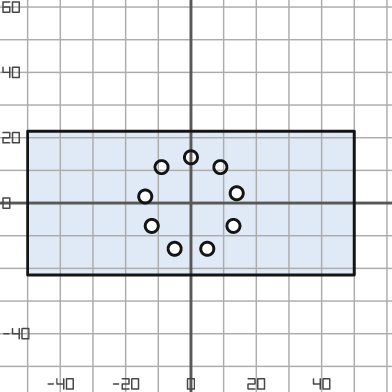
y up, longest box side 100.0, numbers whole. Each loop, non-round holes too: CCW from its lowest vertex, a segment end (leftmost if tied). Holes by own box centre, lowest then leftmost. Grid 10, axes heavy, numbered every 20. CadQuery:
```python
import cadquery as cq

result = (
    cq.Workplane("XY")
    .moveTo(-50.0, -22.0)
    .lineTo(50.0, -22.0)
    .lineTo(50.0, 22.0)
    .lineTo(-50.0, 22.0)
    .close()
    .moveTo(-5.0, -14.0)
    .circle(2.0)
    .moveTo(5.0, -14.0)
    .circle(2.0)
    .moveTo(-12.0, -7.0)
    .circle(2.0)
    .moveTo(13.0, -7.0)
    .circle(2.0)
    .moveTo(-14.0, 2.0)
    .circle(2.0)
    .moveTo(14.0, 3.0)
    .circle(2.0)
    .moveTo(-9.0, 11.0)
    .circle(2.0)
    .moveTo(9.0, 11.0)
    .circle(2.0)
    .moveTo(0.0, 14.0)
    .circle(2.0)
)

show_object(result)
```